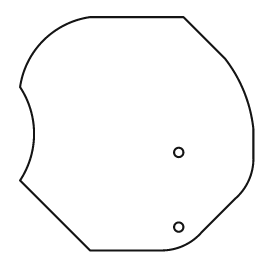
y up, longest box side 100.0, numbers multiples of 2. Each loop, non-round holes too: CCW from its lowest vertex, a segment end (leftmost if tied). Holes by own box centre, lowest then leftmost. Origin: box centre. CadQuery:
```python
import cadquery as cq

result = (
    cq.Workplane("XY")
    .moveTo(-20.0, -50.0)
    .lineTo(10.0, -50.0)
    .threePointArc((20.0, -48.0), (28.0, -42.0))
    .lineTo(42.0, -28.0)
    .threePointArc((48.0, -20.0), (50.0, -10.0))
    .lineTo(50.0, 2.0)
    .threePointArc((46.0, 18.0), (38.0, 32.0))
    .lineTo(20.0, 50.0)
    .lineTo(-20.0, 50.0)
    .threePointArc((-40.0, 40.0), (-50.0, 20.0))
    .threePointArc((-44.0, 0.0), (-50.0, -20.0))
    .close()
    .moveTo(18.0, -40.0)
    .circle(2.0)
    .moveTo(18.0, -8.0)
    .circle(2.0)
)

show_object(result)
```